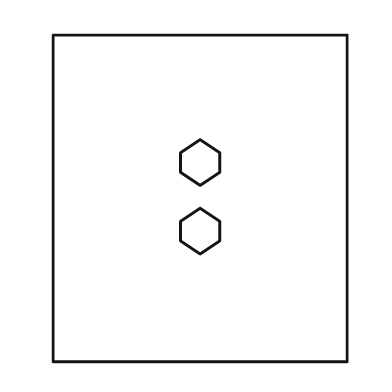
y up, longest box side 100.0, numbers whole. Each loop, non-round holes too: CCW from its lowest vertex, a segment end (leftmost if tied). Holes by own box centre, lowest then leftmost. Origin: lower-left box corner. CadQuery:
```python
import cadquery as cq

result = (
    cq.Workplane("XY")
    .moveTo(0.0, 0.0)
    .lineTo(90.0, 0.0)
    .lineTo(90.0, 100.0)
    .lineTo(0.0, 100.0)
    .close()
    .moveTo(45.0, 33.0)
    .lineTo(51.0, 37.0)
    .lineTo(51.0, 43.0)
    .lineTo(45.0, 47.0)
    .lineTo(39.0, 43.0)
    .lineTo(39.0, 37.0)
    .close()
    .moveTo(45.0, 54.0)
    .lineTo(51.0, 58.0)
    .lineTo(51.0, 64.0)
    .lineTo(45.0, 68.0)
    .lineTo(39.0, 64.0)
    .lineTo(39.0, 58.0)
    .close()
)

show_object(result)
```